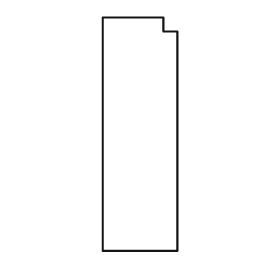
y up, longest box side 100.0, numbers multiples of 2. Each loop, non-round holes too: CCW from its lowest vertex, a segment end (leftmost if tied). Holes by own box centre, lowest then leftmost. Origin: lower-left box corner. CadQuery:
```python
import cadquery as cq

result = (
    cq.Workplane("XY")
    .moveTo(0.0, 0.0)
    .lineTo(32.0, 0.0)
    .lineTo(32.0, 94.0)
    .lineTo(26.0, 94.0)
    .lineTo(26.0, 100.0)
    .lineTo(0.0, 100.0)
    .close()
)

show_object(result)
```